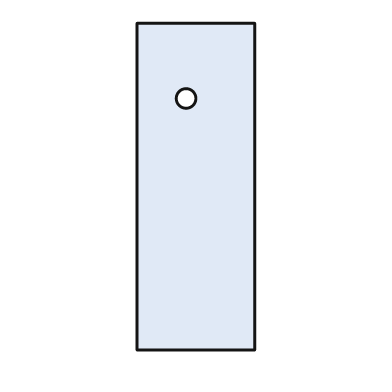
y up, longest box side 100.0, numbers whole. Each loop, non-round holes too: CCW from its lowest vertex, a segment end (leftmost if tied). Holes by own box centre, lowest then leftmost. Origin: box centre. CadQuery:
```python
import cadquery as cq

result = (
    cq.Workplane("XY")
    .moveTo(-18.0, -50.0)
    .lineTo(18.0, -50.0)
    .lineTo(18.0, 50.0)
    .lineTo(-18.0, 50.0)
    .close()
    .moveTo(-3.0, 27.0)
    .circle(3.0)
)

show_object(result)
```